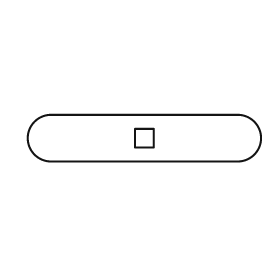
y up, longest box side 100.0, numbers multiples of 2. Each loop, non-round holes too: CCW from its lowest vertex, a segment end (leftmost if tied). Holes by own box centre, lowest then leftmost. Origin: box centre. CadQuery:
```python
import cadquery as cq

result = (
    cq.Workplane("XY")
    .moveTo(-40.0, -10.0)
    .lineTo(40.0, -10.0)
    .threePointArc((50.0, 0.0), (40.0, 10.0))
    .lineTo(-40.0, 10.0)
    .threePointArc((-50.0, 0.0), (-40.0, -10.0))
    .close()
    .moveTo(-4.0, -4.0)
    .lineTo(4.0, -4.0)
    .lineTo(4.0, 4.0)
    .lineTo(-4.0, 4.0)
    .close()
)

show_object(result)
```